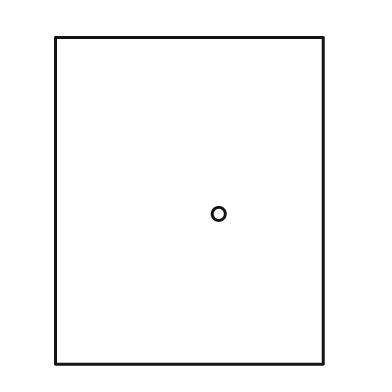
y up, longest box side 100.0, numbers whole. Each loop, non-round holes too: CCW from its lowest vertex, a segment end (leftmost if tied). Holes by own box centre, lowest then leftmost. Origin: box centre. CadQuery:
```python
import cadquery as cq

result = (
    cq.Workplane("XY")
    .moveTo(-41.0, -50.0)
    .lineTo(41.0, -50.0)
    .lineTo(41.0, 50.0)
    .lineTo(-41.0, 50.0)
    .close()
    .moveTo(9.0, -4.0)
    .circle(2.0)
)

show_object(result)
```